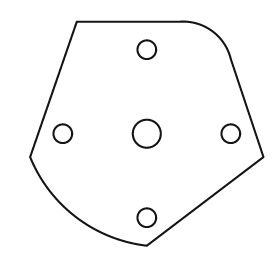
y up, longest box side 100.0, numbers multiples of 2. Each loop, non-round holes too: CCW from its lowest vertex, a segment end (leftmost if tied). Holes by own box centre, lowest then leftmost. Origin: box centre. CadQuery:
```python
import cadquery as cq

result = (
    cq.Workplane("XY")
    .moveTo(0.0, -48.0)
    .lineTo(50.0, -10.0)
    .lineTo(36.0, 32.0)
    .threePointArc((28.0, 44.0), (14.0, 48.0))
    .lineTo(-30.0, 48.0)
    .lineTo(-50.0, -10.0)
    .threePointArc((-30.0, -36.0), (0.0, -48.0))
    .close()
    .moveTo(0.0, -36.0)
    .circle(4.0)
    .moveTo(-36.0, 0.0)
    .circle(4.0)
    .moveTo(0.0, 0.0)
    .circle(6.0)
    .moveTo(36.0, 0.0)
    .circle(4.0)
    .moveTo(0.0, 36.0)
    .circle(4.0)
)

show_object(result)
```